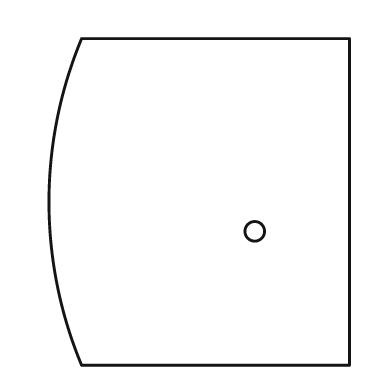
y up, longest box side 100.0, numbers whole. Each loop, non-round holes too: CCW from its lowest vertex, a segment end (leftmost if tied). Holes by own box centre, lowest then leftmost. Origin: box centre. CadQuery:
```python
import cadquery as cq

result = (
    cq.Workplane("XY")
    .moveTo(-36.0, -50.0)
    .lineTo(46.0, -50.0)
    .lineTo(46.0, 50.0)
    .lineTo(-36.0, 50.0)
    .threePointArc((-46.0, 0.0), (-36.0, -50.0))
    .close()
    .moveTo(17.0, -9.0)
    .circle(3.0)
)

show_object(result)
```